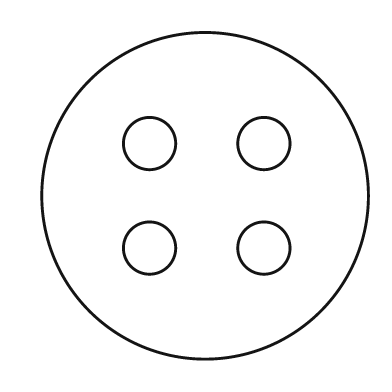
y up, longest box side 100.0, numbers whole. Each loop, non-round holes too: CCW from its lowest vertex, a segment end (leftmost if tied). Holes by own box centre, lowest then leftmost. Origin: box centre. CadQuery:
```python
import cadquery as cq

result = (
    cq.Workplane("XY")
    .moveTo(0.0, 0.0)
    .circle(50.0)
    .moveTo(-17.0, -16.0)
    .circle(8.0)
    .moveTo(18.0, -16.0)
    .circle(8.0)
    .moveTo(-17.0, 16.0)
    .circle(8.0)
    .moveTo(18.0, 16.0)
    .circle(8.0)
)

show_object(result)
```